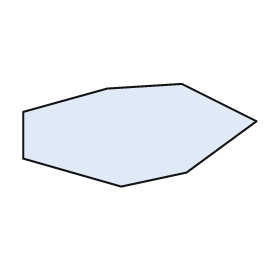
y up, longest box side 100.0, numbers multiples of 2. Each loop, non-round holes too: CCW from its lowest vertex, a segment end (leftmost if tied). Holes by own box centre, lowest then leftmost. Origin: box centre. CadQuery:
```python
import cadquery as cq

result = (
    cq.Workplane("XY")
    .moveTo(-8.0, -22.0)
    .lineTo(20.0, -16.0)
    .lineTo(50.0, 6.0)
    .lineTo(18.0, 22.0)
    .lineTo(-14.0, 20.0)
    .lineTo(-50.0, 10.0)
    .lineTo(-50.0, -10.0)
    .close()
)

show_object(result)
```